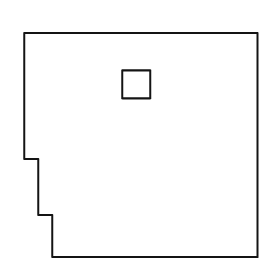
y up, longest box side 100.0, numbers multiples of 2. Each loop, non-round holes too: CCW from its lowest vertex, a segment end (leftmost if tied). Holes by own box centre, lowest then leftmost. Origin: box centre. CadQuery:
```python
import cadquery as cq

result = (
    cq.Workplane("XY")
    .moveTo(-38.0, -48.0)
    .lineTo(50.0, -48.0)
    .lineTo(50.0, 48.0)
    .lineTo(-50.0, 48.0)
    .lineTo(-50.0, -6.0)
    .lineTo(-44.0, -6.0)
    .lineTo(-44.0, -30.0)
    .lineTo(-38.0, -30.0)
    .close()
    .moveTo(-8.0, 20.0)
    .lineTo(4.0, 20.0)
    .lineTo(4.0, 32.0)
    .lineTo(-8.0, 32.0)
    .close()
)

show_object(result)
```